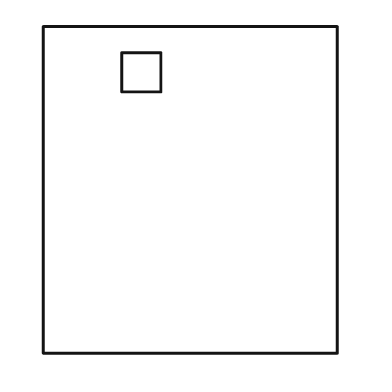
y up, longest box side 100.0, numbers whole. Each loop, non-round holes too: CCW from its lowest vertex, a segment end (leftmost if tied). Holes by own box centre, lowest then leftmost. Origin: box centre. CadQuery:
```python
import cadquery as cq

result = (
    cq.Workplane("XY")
    .moveTo(-45.0, -50.0)
    .lineTo(45.0, -50.0)
    .lineTo(45.0, 50.0)
    .lineTo(-45.0, 50.0)
    .close()
    .moveTo(-21.0, 30.0)
    .lineTo(-9.0, 30.0)
    .lineTo(-9.0, 42.0)
    .lineTo(-21.0, 42.0)
    .close()
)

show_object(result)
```